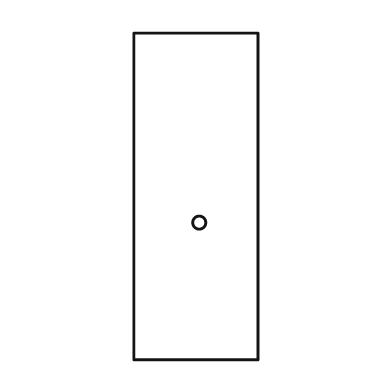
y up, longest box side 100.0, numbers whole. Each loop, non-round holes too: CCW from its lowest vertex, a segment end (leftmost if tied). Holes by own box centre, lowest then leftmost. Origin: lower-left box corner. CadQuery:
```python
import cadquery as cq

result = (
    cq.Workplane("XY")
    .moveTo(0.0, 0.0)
    .lineTo(38.0, 0.0)
    .lineTo(38.0, 100.0)
    .lineTo(0.0, 100.0)
    .close()
    .moveTo(20.0, 42.0)
    .circle(2.0)
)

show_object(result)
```